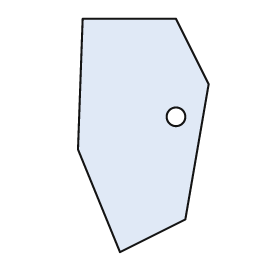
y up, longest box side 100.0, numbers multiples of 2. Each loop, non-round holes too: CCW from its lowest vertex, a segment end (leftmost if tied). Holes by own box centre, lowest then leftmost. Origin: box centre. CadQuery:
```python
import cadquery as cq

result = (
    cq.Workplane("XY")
    .moveTo(-10.0, -50.0)
    .lineTo(18.0, -36.0)
    .lineTo(28.0, 22.0)
    .lineTo(14.0, 50.0)
    .lineTo(-26.0, 50.0)
    .lineTo(-28.0, -6.0)
    .close()
    .moveTo(14.0, 8.0)
    .circle(4.0)
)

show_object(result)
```